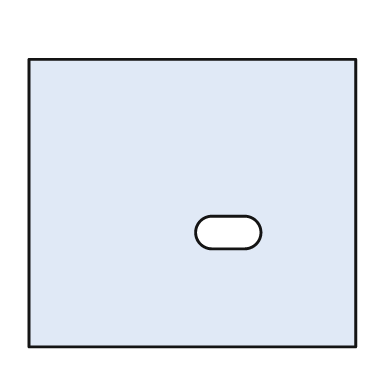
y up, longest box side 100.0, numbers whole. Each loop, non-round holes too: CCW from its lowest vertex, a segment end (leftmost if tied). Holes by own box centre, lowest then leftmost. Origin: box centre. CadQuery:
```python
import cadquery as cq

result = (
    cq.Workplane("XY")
    .moveTo(-50.0, -44.0)
    .lineTo(50.0, -44.0)
    .lineTo(50.0, 44.0)
    .lineTo(-50.0, 44.0)
    .close()
    .moveTo(6.0, -14.0)
    .lineTo(16.0, -14.0)
    .threePointArc((21.0, -9.0), (16.0, -4.0))
    .lineTo(6.0, -4.0)
    .threePointArc((1.0, -9.0), (6.0, -14.0))
    .close()
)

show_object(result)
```